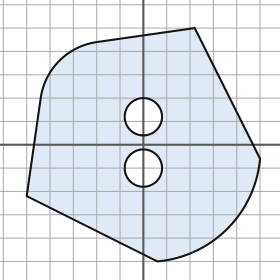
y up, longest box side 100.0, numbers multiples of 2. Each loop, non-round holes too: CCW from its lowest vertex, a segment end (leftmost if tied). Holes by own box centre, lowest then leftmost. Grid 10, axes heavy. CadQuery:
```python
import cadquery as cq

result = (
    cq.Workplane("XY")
    .moveTo(6.0, -50.0)
    .threePointArc((36.0, -36.0), (50.0, -6.0))
    .lineTo(22.0, 50.0)
    .lineTo(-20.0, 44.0)
    .threePointArc((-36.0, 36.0), (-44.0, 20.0))
    .lineTo(-50.0, -22.0)
    .close()
    .moveTo(0.0, -10.0)
    .circle(8.0)
    .moveTo(0.0, 12.0)
    .circle(8.0)
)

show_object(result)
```